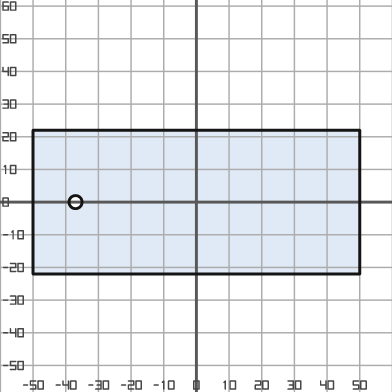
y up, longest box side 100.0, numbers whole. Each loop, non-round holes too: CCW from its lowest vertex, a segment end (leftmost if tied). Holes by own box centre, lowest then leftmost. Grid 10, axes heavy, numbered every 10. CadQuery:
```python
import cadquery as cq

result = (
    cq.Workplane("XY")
    .moveTo(-50.0, -22.0)
    .lineTo(50.0, -22.0)
    .lineTo(50.0, 22.0)
    .lineTo(-50.0, 22.0)
    .close()
    .moveTo(-37.0, 0.0)
    .circle(2.0)
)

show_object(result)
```